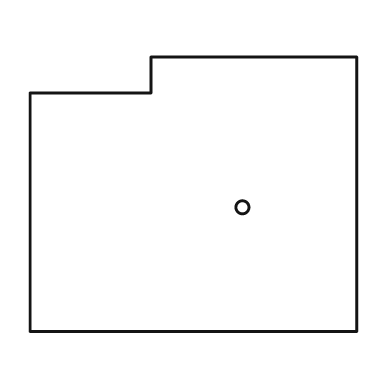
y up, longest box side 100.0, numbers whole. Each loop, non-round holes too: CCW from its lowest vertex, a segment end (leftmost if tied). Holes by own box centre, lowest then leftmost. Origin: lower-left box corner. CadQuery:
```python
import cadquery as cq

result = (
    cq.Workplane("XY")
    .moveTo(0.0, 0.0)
    .lineTo(100.0, 0.0)
    .lineTo(100.0, 84.0)
    .lineTo(37.0, 84.0)
    .lineTo(37.0, 73.0)
    .lineTo(0.0, 73.0)
    .close()
    .moveTo(65.0, 38.0)
    .circle(2.0)
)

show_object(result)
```